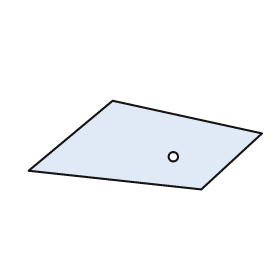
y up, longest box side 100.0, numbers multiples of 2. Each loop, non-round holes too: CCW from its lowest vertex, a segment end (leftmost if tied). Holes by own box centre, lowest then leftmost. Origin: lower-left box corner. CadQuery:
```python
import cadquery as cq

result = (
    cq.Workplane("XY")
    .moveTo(74.0, 0.0)
    .lineTo(100.0, 24.0)
    .lineTo(36.0, 38.0)
    .lineTo(0.0, 8.0)
    .close()
    .moveTo(62.0, 14.0)
    .circle(2.0)
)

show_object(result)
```